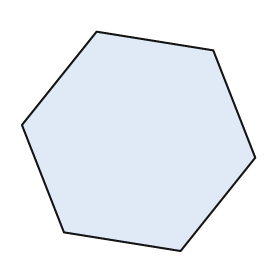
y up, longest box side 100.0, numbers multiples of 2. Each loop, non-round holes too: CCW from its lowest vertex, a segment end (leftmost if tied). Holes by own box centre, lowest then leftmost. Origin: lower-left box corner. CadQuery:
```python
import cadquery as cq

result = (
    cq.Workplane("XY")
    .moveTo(68.0, 0.0)
    .lineTo(100.0, 40.0)
    .lineTo(82.0, 86.0)
    .lineTo(32.0, 94.0)
    .lineTo(0.0, 54.0)
    .lineTo(18.0, 8.0)
    .close()
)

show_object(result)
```